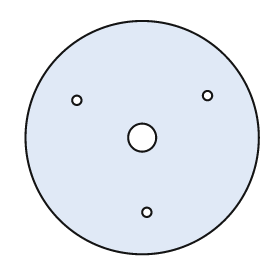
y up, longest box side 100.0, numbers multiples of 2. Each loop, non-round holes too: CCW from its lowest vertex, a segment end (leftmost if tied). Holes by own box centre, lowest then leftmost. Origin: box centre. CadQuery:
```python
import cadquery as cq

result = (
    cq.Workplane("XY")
    .moveTo(0.0, 0.0)
    .circle(50.0)
    .moveTo(2.0, -32.0)
    .circle(2.0)
    .moveTo(0.0, 0.0)
    .circle(6.0)
    .moveTo(-28.0, 16.0)
    .circle(2.0)
    .moveTo(28.0, 18.0)
    .circle(2.0)
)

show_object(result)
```